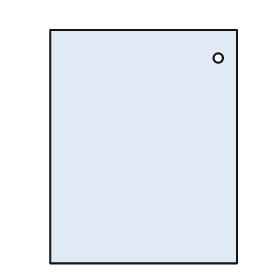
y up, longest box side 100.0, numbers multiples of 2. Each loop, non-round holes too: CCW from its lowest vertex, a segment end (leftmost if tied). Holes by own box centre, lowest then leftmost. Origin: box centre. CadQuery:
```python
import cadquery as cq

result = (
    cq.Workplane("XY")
    .moveTo(-40.0, -50.0)
    .lineTo(40.0, -50.0)
    .lineTo(40.0, 50.0)
    .lineTo(-40.0, 50.0)
    .close()
    .moveTo(32.0, 38.0)
    .circle(2.0)
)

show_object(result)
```